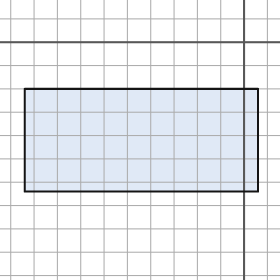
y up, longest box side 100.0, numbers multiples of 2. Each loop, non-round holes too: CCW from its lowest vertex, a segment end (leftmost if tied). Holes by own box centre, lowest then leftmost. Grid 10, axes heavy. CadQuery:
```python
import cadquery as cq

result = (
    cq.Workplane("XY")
    .moveTo(-94.0, -64.0)
    .lineTo(6.0, -64.0)
    .lineTo(6.0, -20.0)
    .lineTo(-94.0, -20.0)
    .close()
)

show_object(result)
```